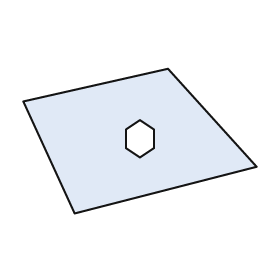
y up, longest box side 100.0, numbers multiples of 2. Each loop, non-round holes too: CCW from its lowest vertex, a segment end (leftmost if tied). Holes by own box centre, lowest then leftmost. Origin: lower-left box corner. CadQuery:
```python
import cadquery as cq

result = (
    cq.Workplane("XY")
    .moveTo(22.0, 0.0)
    .lineTo(100.0, 20.0)
    .lineTo(62.0, 62.0)
    .lineTo(0.0, 48.0)
    .close()
    .moveTo(50.0, 24.0)
    .lineTo(56.0, 28.0)
    .lineTo(56.0, 36.0)
    .lineTo(50.0, 40.0)
    .lineTo(44.0, 36.0)
    .lineTo(44.0, 28.0)
    .close()
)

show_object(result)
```